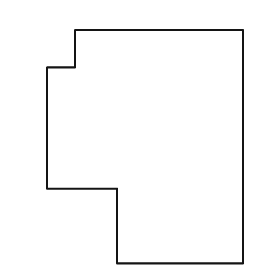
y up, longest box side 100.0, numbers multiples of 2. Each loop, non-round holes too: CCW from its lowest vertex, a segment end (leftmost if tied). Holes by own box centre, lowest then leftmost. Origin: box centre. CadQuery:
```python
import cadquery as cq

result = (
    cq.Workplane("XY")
    .moveTo(-12.0, -50.0)
    .lineTo(42.0, -50.0)
    .lineTo(42.0, 50.0)
    .lineTo(-30.0, 50.0)
    .lineTo(-30.0, 34.0)
    .lineTo(-42.0, 34.0)
    .lineTo(-42.0, -18.0)
    .lineTo(-12.0, -18.0)
    .close()
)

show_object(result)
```